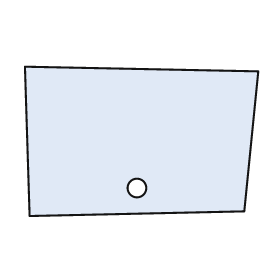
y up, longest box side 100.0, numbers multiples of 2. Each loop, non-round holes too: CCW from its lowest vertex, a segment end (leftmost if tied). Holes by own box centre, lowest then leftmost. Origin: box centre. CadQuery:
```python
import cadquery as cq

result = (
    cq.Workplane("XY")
    .moveTo(-48.0, -32.0)
    .lineTo(44.0, -30.0)
    .lineTo(50.0, 30.0)
    .lineTo(-50.0, 32.0)
    .close()
    .moveTo(-2.0, -20.0)
    .circle(4.0)
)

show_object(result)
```